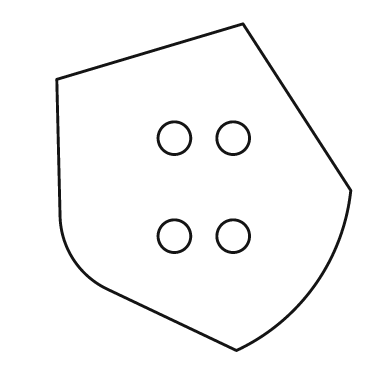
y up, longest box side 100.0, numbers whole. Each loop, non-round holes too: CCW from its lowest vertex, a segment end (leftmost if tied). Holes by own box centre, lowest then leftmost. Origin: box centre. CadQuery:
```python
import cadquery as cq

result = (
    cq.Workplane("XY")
    .moveTo(10.0, -50.0)
    .threePointArc((34.0, -30.0), (45.0, -1.0))
    .lineTo(12.0, 50.0)
    .lineTo(-45.0, 33.0)
    .lineTo(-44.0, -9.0)
    .threePointArc((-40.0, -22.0), (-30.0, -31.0))
    .close()
    .moveTo(-9.0, -15.0)
    .circle(5.0)
    .moveTo(9.0, -15.0)
    .circle(5.0)
    .moveTo(-9.0, 15.0)
    .circle(5.0)
    .moveTo(9.0, 15.0)
    .circle(5.0)
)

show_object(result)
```